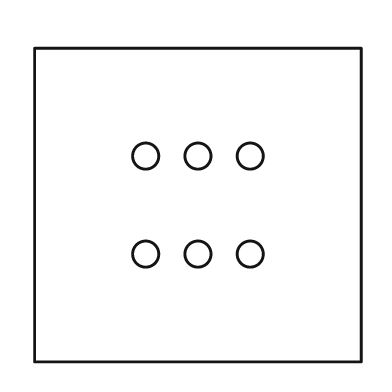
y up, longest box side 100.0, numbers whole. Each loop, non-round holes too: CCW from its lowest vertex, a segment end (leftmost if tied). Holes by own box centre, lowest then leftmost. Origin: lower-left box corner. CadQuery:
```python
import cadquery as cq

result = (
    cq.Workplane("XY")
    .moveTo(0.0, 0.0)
    .lineTo(100.0, 0.0)
    .lineTo(100.0, 96.0)
    .lineTo(0.0, 96.0)
    .close()
    .moveTo(34.0, 33.0)
    .circle(4.0)
    .moveTo(50.0, 33.0)
    .circle(4.0)
    .moveTo(66.0, 33.0)
    .circle(4.0)
    .moveTo(34.0, 63.0)
    .circle(4.0)
    .moveTo(50.0, 63.0)
    .circle(4.0)
    .moveTo(66.0, 63.0)
    .circle(4.0)
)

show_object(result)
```